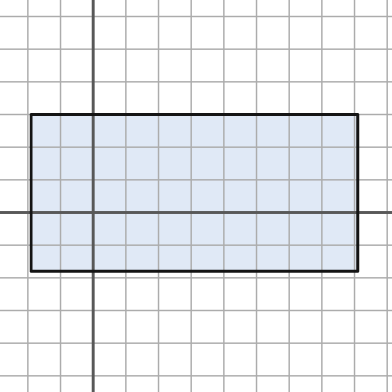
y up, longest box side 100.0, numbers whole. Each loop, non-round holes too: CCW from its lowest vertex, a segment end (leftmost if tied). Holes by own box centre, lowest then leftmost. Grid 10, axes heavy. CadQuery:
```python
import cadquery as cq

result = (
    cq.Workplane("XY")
    .moveTo(-19.0, -18.0)
    .lineTo(81.0, -18.0)
    .lineTo(81.0, 30.0)
    .lineTo(-19.0, 30.0)
    .close()
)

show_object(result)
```